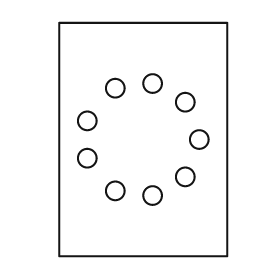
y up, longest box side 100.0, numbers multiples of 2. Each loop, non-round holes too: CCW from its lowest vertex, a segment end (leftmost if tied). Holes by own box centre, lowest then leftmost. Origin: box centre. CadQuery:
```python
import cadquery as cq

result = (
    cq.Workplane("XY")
    .moveTo(-36.0, -50.0)
    .lineTo(36.0, -50.0)
    .lineTo(36.0, 50.0)
    .lineTo(-36.0, 50.0)
    .close()
    .moveTo(4.0, -24.0)
    .circle(4.0)
    .moveTo(-12.0, -22.0)
    .circle(4.0)
    .moveTo(18.0, -16.0)
    .circle(4.0)
    .moveTo(-24.0, -8.0)
    .circle(4.0)
    .moveTo(24.0, 0.0)
    .circle(4.0)
    .moveTo(-24.0, 8.0)
    .circle(4.0)
    .moveTo(18.0, 16.0)
    .circle(4.0)
    .moveTo(-12.0, 22.0)
    .circle(4.0)
    .moveTo(4.0, 24.0)
    .circle(4.0)
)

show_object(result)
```